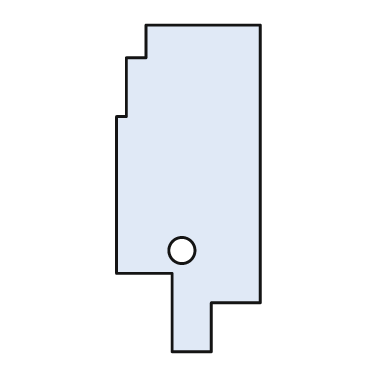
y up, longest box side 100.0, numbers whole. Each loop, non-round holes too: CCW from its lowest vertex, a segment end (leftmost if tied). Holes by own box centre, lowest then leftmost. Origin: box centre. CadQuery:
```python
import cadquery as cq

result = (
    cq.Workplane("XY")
    .moveTo(-5.0, -50.0)
    .lineTo(7.0, -50.0)
    .lineTo(7.0, -35.0)
    .lineTo(22.0, -35.0)
    .lineTo(22.0, 50.0)
    .lineTo(-13.0, 50.0)
    .lineTo(-13.0, 40.0)
    .lineTo(-19.0, 40.0)
    .lineTo(-19.0, 22.0)
    .lineTo(-22.0, 22.0)
    .lineTo(-22.0, -26.0)
    .lineTo(-5.0, -26.0)
    .close()
    .moveTo(-2.0, -19.0)
    .circle(4.0)
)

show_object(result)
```